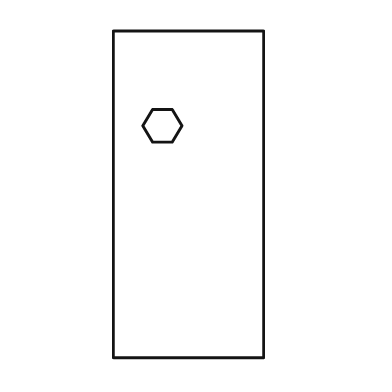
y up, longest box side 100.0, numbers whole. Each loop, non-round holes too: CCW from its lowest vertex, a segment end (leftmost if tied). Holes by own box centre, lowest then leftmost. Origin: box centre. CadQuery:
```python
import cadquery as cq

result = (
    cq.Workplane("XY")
    .moveTo(-23.0, -50.0)
    .lineTo(23.0, -50.0)
    .lineTo(23.0, 50.0)
    .lineTo(-23.0, 50.0)
    .close()
    .moveTo(-11.0, 16.0)
    .lineTo(-5.0, 16.0)
    .lineTo(-2.0, 21.0)
    .lineTo(-5.0, 26.0)
    .lineTo(-11.0, 26.0)
    .lineTo(-14.0, 21.0)
    .close()
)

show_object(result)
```